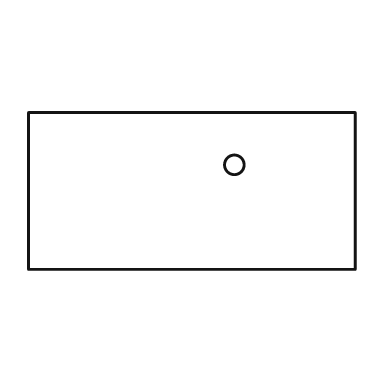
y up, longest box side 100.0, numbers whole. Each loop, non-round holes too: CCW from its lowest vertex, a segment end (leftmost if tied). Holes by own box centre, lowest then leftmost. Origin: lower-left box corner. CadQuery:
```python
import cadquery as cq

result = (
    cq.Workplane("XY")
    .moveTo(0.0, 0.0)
    .lineTo(100.0, 0.0)
    .lineTo(100.0, 48.0)
    .lineTo(0.0, 48.0)
    .close()
    .moveTo(63.0, 32.0)
    .circle(3.0)
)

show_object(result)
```